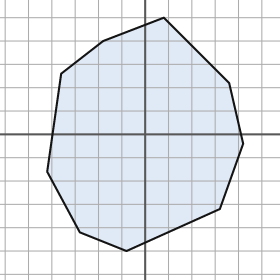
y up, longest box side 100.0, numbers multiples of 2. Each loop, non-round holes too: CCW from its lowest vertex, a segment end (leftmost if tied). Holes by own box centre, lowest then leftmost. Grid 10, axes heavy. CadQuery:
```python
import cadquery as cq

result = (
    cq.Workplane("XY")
    .moveTo(-8.0, -50.0)
    .lineTo(32.0, -32.0)
    .lineTo(42.0, -4.0)
    .lineTo(36.0, 22.0)
    .lineTo(8.0, 50.0)
    .lineTo(-18.0, 40.0)
    .lineTo(-36.0, 26.0)
    .lineTo(-42.0, -16.0)
    .lineTo(-28.0, -42.0)
    .close()
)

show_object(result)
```